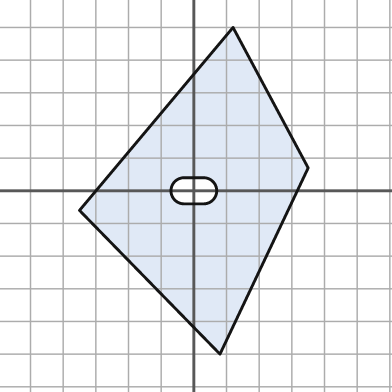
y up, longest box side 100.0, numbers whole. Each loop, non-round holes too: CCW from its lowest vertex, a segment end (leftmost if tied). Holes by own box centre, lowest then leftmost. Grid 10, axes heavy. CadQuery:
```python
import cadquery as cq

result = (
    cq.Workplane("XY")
    .moveTo(8.0, -50.0)
    .lineTo(35.0, 7.0)
    .lineTo(12.0, 50.0)
    .lineTo(-35.0, -6.0)
    .close()
    .moveTo(-3.0, -4.0)
    .lineTo(3.0, -4.0)
    .threePointArc((7.0, 0.0), (3.0, 4.0))
    .lineTo(-3.0, 4.0)
    .threePointArc((-7.0, 0.0), (-3.0, -4.0))
    .close()
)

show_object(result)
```